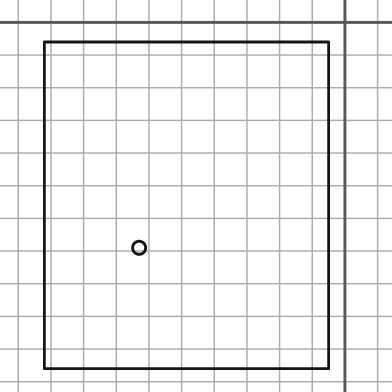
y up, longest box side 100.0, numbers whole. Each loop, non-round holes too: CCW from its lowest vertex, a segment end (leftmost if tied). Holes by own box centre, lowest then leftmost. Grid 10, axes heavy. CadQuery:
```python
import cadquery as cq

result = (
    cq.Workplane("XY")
    .moveTo(-92.0, -106.0)
    .lineTo(-5.0, -106.0)
    .lineTo(-5.0, -6.0)
    .lineTo(-92.0, -6.0)
    .close()
    .moveTo(-63.0, -69.0)
    .circle(2.0)
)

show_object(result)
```